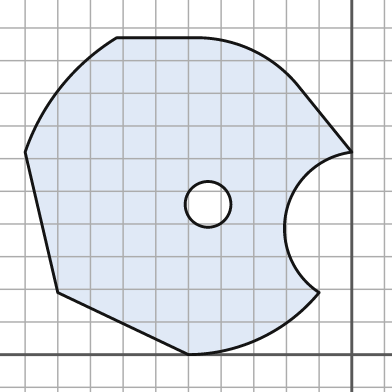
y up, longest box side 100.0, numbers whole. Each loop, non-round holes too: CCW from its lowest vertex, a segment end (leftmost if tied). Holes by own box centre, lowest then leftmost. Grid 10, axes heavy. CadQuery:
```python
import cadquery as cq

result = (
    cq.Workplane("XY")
    .moveTo(-50.0, 0.0)
    .threePointArc((-28.0, 5.0), (-10.0, 19.0))
    .threePointArc((-20.0, 44.0), (0.0, 62.0))
    .lineTo(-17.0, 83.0)
    .threePointArc((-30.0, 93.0), (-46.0, 97.0))
    .lineTo(-72.0, 97.0)
    .threePointArc((-89.0, 82.0), (-100.0, 62.0))
    .lineTo(-90.0, 19.0)
    .close()
    .moveTo(-44.0, 46.0)
    .circle(7.0)
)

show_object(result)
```